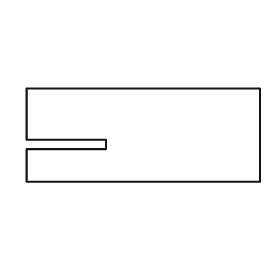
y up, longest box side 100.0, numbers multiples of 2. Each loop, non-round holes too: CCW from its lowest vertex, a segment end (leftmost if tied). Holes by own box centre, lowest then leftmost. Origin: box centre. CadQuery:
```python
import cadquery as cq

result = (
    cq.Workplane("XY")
    .moveTo(-50.0, -20.0)
    .lineTo(50.0, -20.0)
    .lineTo(50.0, 20.0)
    .lineTo(-50.0, 20.0)
    .lineTo(-50.0, -2.0)
    .lineTo(-16.0, -2.0)
    .lineTo(-16.0, -6.0)
    .lineTo(-50.0, -6.0)
    .close()
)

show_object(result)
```